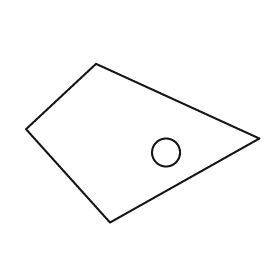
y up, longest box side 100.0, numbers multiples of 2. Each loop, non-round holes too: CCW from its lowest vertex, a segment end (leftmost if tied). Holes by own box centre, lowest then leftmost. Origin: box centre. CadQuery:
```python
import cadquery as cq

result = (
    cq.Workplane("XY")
    .moveTo(-14.0, -34.0)
    .lineTo(50.0, 2.0)
    .lineTo(-20.0, 34.0)
    .lineTo(-50.0, 6.0)
    .close()
    .moveTo(10.0, -4.0)
    .circle(6.0)
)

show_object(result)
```